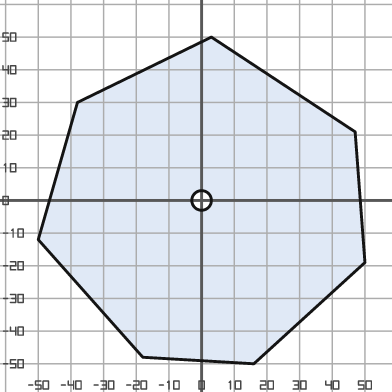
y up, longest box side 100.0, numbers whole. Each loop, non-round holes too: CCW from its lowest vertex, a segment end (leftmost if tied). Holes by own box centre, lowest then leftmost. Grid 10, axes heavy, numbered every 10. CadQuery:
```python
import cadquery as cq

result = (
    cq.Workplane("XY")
    .moveTo(16.0, -50.0)
    .lineTo(50.0, -19.0)
    .lineTo(47.0, 21.0)
    .lineTo(3.0, 50.0)
    .lineTo(-38.0, 30.0)
    .lineTo(-50.0, -12.0)
    .lineTo(-18.0, -48.0)
    .close()
    .moveTo(0.0, 0.0)
    .circle(3.0)
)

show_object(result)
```